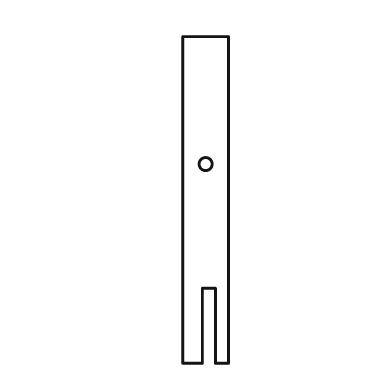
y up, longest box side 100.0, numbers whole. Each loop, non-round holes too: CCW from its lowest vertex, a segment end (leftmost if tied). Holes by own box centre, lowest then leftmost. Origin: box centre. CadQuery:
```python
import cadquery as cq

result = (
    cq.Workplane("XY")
    .moveTo(-7.0, -50.0)
    .lineTo(-1.0, -50.0)
    .lineTo(-1.0, -27.0)
    .lineTo(3.0, -27.0)
    .lineTo(3.0, -50.0)
    .lineTo(7.0, -50.0)
    .lineTo(7.0, 50.0)
    .lineTo(-7.0, 50.0)
    .close()
    .moveTo(0.0, 11.0)
    .circle(2.0)
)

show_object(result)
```